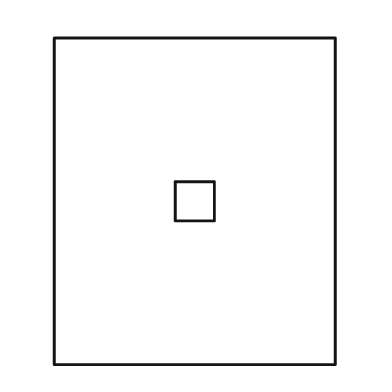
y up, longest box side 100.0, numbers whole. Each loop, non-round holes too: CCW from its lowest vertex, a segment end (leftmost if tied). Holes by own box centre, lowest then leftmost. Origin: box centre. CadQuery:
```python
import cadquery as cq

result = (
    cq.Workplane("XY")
    .moveTo(-43.0, -50.0)
    .lineTo(43.0, -50.0)
    .lineTo(43.0, 50.0)
    .lineTo(-43.0, 50.0)
    .close()
    .moveTo(-6.0, -6.0)
    .lineTo(6.0, -6.0)
    .lineTo(6.0, 6.0)
    .lineTo(-6.0, 6.0)
    .close()
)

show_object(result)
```